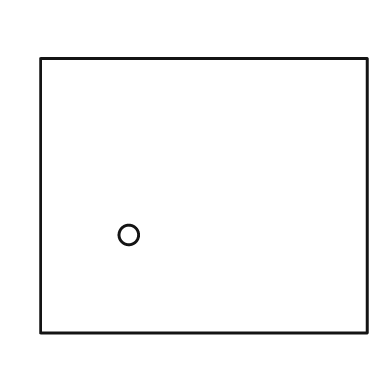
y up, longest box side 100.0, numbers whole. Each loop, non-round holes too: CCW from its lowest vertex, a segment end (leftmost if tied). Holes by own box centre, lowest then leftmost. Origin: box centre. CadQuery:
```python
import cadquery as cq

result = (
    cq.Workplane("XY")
    .moveTo(-50.0, -42.0)
    .lineTo(50.0, -42.0)
    .lineTo(50.0, 42.0)
    .lineTo(-50.0, 42.0)
    .close()
    .moveTo(-23.0, -12.0)
    .circle(3.0)
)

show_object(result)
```